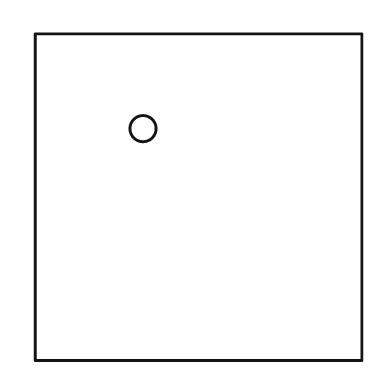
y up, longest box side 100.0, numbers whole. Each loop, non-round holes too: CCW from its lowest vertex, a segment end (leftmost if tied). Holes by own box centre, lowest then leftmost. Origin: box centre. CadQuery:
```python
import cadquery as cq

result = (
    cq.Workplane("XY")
    .moveTo(-50.0, -50.0)
    .lineTo(50.0, -50.0)
    .lineTo(50.0, 50.0)
    .lineTo(-50.0, 50.0)
    .close()
    .moveTo(-17.0, 21.0)
    .circle(4.0)
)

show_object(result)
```